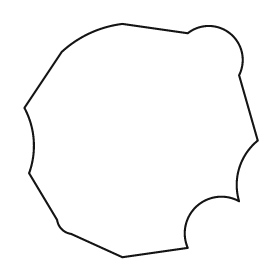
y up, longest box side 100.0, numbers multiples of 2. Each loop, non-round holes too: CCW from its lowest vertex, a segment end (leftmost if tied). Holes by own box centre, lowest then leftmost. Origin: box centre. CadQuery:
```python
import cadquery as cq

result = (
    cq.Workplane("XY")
    .moveTo(-8.0, -50.0)
    .lineTo(20.0, -46.0)
    .threePointArc((24.0, -28.0), (42.0, -26.0))
    .threePointArc((42.0, -12.0), (50.0, 0.0))
    .lineTo(42.0, 28.0)
    .threePointArc((38.0, 46.0), (20.0, 46.0))
    .lineTo(-8.0, 50.0)
    .threePointArc((-22.0, 46.0), (-34.0, 38.0))
    .lineTo(-50.0, 14.0)
    .threePointArc((-46.0, 0.0), (-48.0, -14.0))
    .lineTo(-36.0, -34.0)
    .threePointArc((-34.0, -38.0), (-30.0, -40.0))
    .close()
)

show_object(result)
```